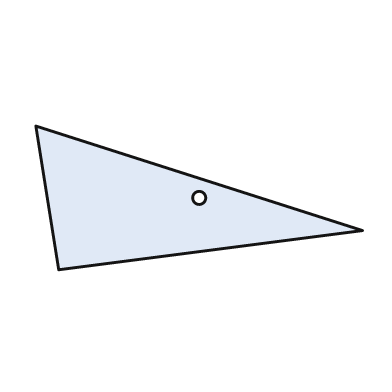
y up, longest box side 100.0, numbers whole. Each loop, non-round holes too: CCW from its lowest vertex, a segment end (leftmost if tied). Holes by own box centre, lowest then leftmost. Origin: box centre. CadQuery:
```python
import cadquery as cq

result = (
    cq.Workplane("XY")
    .moveTo(-43.0, -22.0)
    .lineTo(50.0, -10.0)
    .lineTo(-50.0, 22.0)
    .close()
    .moveTo(0.0, 0.0)
    .circle(2.0)
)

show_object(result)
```